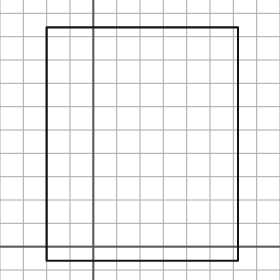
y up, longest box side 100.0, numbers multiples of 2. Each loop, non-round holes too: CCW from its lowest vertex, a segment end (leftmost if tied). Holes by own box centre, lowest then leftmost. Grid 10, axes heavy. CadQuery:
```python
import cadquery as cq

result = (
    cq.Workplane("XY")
    .moveTo(-20.0, -6.0)
    .lineTo(62.0, -6.0)
    .lineTo(62.0, 94.0)
    .lineTo(-20.0, 94.0)
    .close()
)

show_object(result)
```